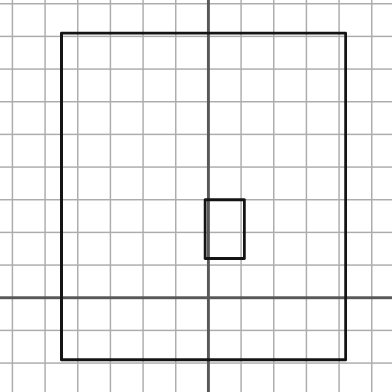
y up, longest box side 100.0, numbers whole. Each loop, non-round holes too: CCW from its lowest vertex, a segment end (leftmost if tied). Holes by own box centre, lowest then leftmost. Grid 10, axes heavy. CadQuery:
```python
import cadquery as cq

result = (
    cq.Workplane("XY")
    .moveTo(-45.0, -19.0)
    .lineTo(42.0, -19.0)
    .lineTo(42.0, 81.0)
    .lineTo(-45.0, 81.0)
    .close()
    .moveTo(-1.0, 12.0)
    .lineTo(11.0, 12.0)
    .lineTo(11.0, 30.0)
    .lineTo(-1.0, 30.0)
    .close()
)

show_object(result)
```